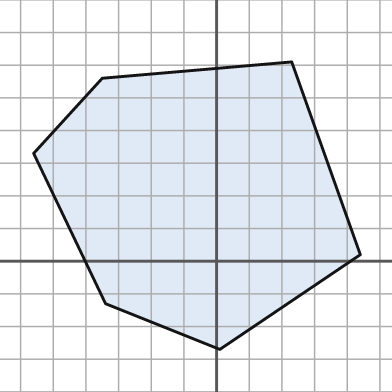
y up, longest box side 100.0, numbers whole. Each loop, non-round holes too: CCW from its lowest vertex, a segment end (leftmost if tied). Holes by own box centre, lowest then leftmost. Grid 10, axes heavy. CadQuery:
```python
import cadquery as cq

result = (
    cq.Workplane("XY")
    .moveTo(1.0, -27.0)
    .lineTo(44.0, 2.0)
    .lineTo(23.0, 61.0)
    .lineTo(-35.0, 56.0)
    .lineTo(-56.0, 33.0)
    .lineTo(-34.0, -13.0)
    .close()
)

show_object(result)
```